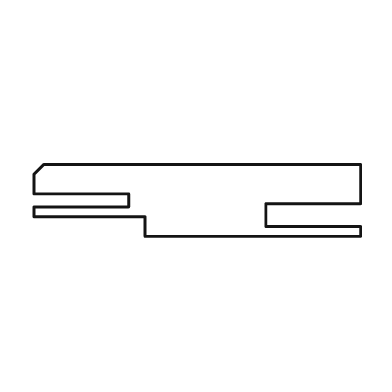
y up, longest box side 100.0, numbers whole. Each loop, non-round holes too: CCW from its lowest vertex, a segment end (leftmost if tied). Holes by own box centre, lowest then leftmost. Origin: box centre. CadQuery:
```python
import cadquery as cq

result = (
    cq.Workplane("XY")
    .moveTo(-16.0, -11.0)
    .lineTo(50.0, -11.0)
    .lineTo(50.0, -8.0)
    .lineTo(21.0, -8.0)
    .lineTo(21.0, -1.0)
    .lineTo(50.0, -1.0)
    .lineTo(50.0, 11.0)
    .lineTo(-47.0, 11.0)
    .lineTo(-50.0, 8.0)
    .lineTo(-50.0, 2.0)
    .lineTo(-21.0, 2.0)
    .lineTo(-21.0, -2.0)
    .lineTo(-50.0, -2.0)
    .lineTo(-50.0, -5.0)
    .lineTo(-16.0, -5.0)
    .close()
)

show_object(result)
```